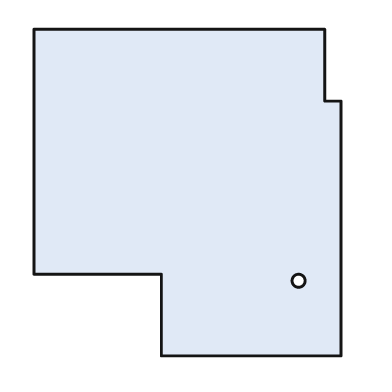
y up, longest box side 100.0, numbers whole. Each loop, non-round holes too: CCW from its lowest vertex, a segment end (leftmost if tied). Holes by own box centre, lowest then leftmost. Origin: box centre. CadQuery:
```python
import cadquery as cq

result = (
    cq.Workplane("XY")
    .moveTo(-8.0, -50.0)
    .lineTo(47.0, -50.0)
    .lineTo(47.0, 28.0)
    .lineTo(42.0, 28.0)
    .lineTo(42.0, 50.0)
    .lineTo(-47.0, 50.0)
    .lineTo(-47.0, -25.0)
    .lineTo(-8.0, -25.0)
    .close()
    .moveTo(34.0, -27.0)
    .circle(2.0)
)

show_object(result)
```